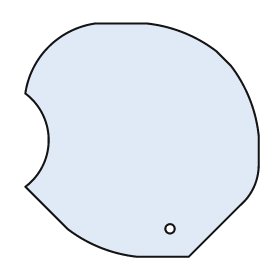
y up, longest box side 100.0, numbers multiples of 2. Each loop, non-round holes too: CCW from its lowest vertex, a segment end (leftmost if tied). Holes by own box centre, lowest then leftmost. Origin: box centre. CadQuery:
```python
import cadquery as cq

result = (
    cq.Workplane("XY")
    .moveTo(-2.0, -50.0)
    .lineTo(20.0, -50.0)
    .lineTo(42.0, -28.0)
    .threePointArc((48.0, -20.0), (50.0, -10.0))
    .lineTo(50.0, 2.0)
    .threePointArc((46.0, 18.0), (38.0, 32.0))
    .lineTo(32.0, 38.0)
    .threePointArc((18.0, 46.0), (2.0, 50.0))
    .lineTo(-20.0, 50.0)
    .threePointArc((-40.0, 40.0), (-50.0, 20.0))
    .threePointArc((-40.0, 0.0), (-50.0, -20.0))
    .lineTo(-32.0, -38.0)
    .threePointArc((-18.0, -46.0), (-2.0, -50.0))
    .close()
    .moveTo(12.0, -38.0)
    .circle(2.0)
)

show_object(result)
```